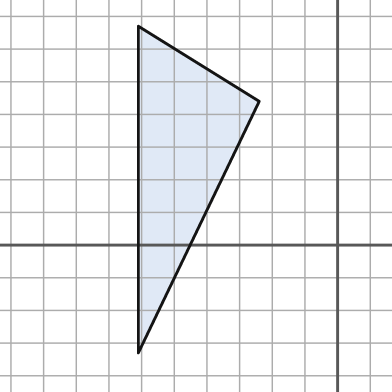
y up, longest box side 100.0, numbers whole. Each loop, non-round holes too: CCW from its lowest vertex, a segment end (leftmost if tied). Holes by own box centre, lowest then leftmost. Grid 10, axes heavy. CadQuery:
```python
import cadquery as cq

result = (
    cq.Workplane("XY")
    .moveTo(-61.0, -33.0)
    .lineTo(-24.0, 44.0)
    .lineTo(-61.0, 67.0)
    .close()
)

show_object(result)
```